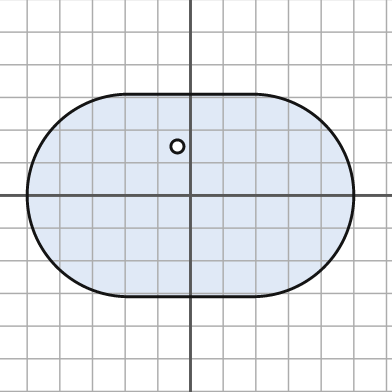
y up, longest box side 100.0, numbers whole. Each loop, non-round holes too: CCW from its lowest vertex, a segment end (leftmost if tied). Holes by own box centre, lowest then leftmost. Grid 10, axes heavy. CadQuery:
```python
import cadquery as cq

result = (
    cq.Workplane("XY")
    .moveTo(-19.0, -31.0)
    .lineTo(19.0, -31.0)
    .threePointArc((50.0, 0.0), (19.0, 31.0))
    .lineTo(-19.0, 31.0)
    .threePointArc((-50.0, 0.0), (-19.0, -31.0))
    .close()
    .moveTo(-4.0, 15.0)
    .circle(2.0)
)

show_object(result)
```